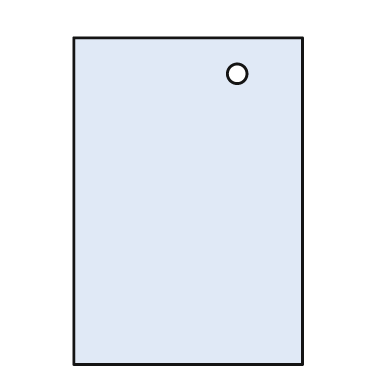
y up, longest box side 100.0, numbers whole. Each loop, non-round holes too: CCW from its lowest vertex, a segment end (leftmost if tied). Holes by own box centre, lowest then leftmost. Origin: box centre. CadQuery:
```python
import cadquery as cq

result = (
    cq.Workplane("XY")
    .moveTo(-35.0, -50.0)
    .lineTo(35.0, -50.0)
    .lineTo(35.0, 50.0)
    .lineTo(-35.0, 50.0)
    .close()
    .moveTo(15.0, 39.0)
    .circle(3.0)
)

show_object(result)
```